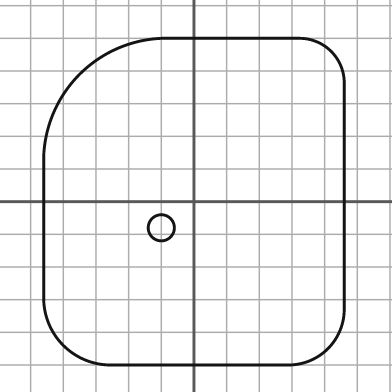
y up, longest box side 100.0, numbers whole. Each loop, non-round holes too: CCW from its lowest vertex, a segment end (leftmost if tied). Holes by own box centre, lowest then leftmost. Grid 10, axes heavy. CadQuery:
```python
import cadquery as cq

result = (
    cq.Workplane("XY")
    .moveTo(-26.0, -50.0)
    .lineTo(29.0, -50.0)
    .threePointArc((41.0, -45.0), (46.0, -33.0))
    .lineTo(46.0, 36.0)
    .threePointArc((42.0, 46.0), (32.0, 50.0))
    .lineTo(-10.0, 50.0)
    .threePointArc((-35.0, 39.0), (-46.0, 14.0))
    .lineTo(-46.0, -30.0)
    .threePointArc((-40.0, -44.0), (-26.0, -50.0))
    .close()
    .moveTo(-10.0, -8.0)
    .circle(4.0)
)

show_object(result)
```